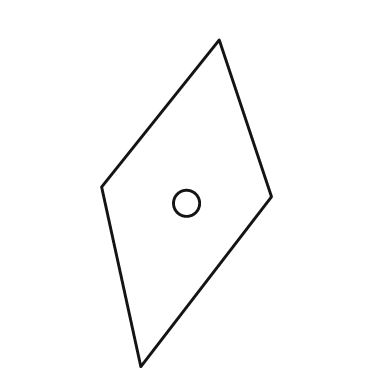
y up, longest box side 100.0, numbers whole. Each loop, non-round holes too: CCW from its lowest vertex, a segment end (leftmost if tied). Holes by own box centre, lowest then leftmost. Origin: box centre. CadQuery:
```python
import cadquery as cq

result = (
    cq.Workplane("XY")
    .moveTo(-14.0, -50.0)
    .lineTo(26.0, 2.0)
    .lineTo(10.0, 50.0)
    .lineTo(-26.0, 5.0)
    .close()
    .moveTo(0.0, 0.0)
    .circle(4.0)
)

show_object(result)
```